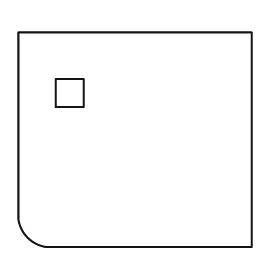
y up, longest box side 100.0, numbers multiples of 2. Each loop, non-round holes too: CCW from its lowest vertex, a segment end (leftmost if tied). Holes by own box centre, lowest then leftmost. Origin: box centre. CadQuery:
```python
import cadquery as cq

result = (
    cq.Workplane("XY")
    .moveTo(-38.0, -46.0)
    .lineTo(50.0, -46.0)
    .lineTo(50.0, 46.0)
    .lineTo(-50.0, 46.0)
    .lineTo(-50.0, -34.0)
    .threePointArc((-46.0, -42.0), (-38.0, -46.0))
    .close()
    .moveTo(-34.0, 14.0)
    .lineTo(-22.0, 14.0)
    .lineTo(-22.0, 26.0)
    .lineTo(-34.0, 26.0)
    .close()
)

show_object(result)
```